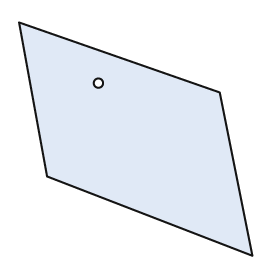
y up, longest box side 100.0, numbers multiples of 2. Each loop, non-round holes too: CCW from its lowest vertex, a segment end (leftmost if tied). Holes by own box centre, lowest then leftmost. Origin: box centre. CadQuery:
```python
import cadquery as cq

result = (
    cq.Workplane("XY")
    .moveTo(50.0, -50.0)
    .lineTo(36.0, 20.0)
    .lineTo(-50.0, 50.0)
    .lineTo(-38.0, -16.0)
    .close()
    .moveTo(-16.0, 24.0)
    .circle(2.0)
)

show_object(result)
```